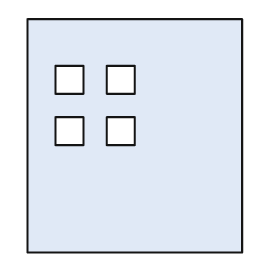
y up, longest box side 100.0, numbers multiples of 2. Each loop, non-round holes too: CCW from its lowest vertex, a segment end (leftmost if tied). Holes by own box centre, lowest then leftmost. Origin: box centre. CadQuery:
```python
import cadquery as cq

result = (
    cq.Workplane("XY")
    .moveTo(-46.0, -50.0)
    .lineTo(46.0, -50.0)
    .lineTo(46.0, 50.0)
    .lineTo(-46.0, 50.0)
    .close()
    .moveTo(-34.0, -4.0)
    .lineTo(-22.0, -4.0)
    .lineTo(-22.0, 8.0)
    .lineTo(-34.0, 8.0)
    .close()
    .moveTo(-12.0, -4.0)
    .lineTo(0.0, -4.0)
    .lineTo(0.0, 8.0)
    .lineTo(-12.0, 8.0)
    .close()
    .moveTo(-34.0, 18.0)
    .lineTo(-22.0, 18.0)
    .lineTo(-22.0, 30.0)
    .lineTo(-34.0, 30.0)
    .close()
    .moveTo(-12.0, 18.0)
    .lineTo(0.0, 18.0)
    .lineTo(0.0, 30.0)
    .lineTo(-12.0, 30.0)
    .close()
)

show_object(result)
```